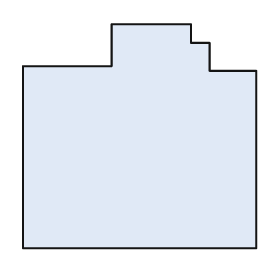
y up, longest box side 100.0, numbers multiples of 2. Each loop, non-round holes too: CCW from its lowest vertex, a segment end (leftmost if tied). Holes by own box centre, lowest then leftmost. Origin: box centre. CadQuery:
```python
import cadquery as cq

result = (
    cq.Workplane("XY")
    .moveTo(-50.0, -48.0)
    .lineTo(50.0, -48.0)
    .lineTo(50.0, 28.0)
    .lineTo(30.0, 28.0)
    .lineTo(30.0, 40.0)
    .lineTo(22.0, 40.0)
    .lineTo(22.0, 48.0)
    .lineTo(-12.0, 48.0)
    .lineTo(-12.0, 30.0)
    .lineTo(-50.0, 30.0)
    .close()
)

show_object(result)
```